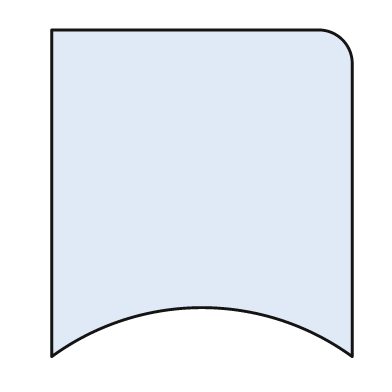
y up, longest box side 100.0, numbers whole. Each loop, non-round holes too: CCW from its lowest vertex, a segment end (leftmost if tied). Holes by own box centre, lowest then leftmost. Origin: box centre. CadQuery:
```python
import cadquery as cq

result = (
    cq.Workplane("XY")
    .moveTo(-46.0, -50.0)
    .threePointArc((0.0, -35.0), (46.0, -50.0))
    .lineTo(46.0, 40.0)
    .threePointArc((43.0, 47.0), (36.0, 50.0))
    .lineTo(-46.0, 50.0)
    .close()
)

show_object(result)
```